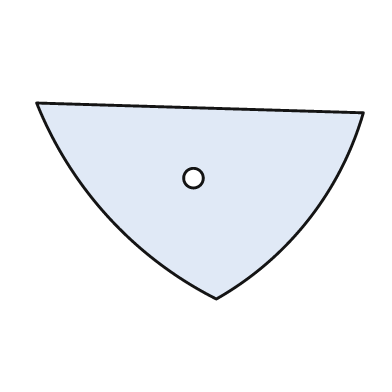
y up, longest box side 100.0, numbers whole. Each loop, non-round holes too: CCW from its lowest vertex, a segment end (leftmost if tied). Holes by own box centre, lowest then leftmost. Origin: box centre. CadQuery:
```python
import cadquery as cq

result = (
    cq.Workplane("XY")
    .moveTo(5.0, -30.0)
    .threePointArc((33.0, -6.0), (50.0, 27.0))
    .lineTo(-50.0, 30.0)
    .threePointArc((-28.0, -5.0), (5.0, -30.0))
    .close()
    .moveTo(-2.0, 7.0)
    .circle(3.0)
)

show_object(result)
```